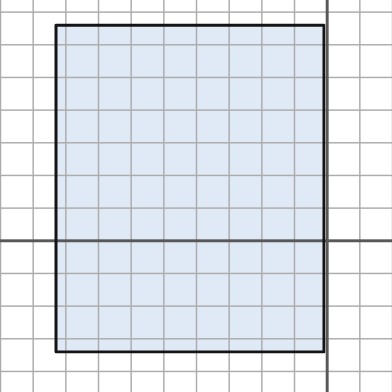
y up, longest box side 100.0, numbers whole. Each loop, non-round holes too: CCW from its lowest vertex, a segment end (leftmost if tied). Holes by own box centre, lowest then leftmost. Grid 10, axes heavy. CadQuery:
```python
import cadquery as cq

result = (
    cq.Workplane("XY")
    .moveTo(-83.0, -34.0)
    .lineTo(-1.0, -34.0)
    .lineTo(-1.0, 66.0)
    .lineTo(-83.0, 66.0)
    .close()
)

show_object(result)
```